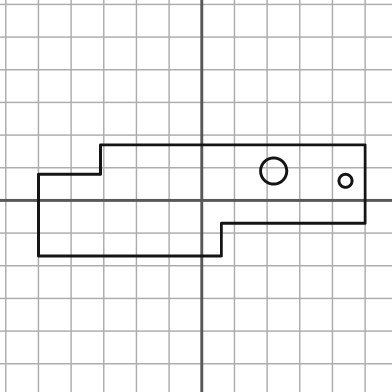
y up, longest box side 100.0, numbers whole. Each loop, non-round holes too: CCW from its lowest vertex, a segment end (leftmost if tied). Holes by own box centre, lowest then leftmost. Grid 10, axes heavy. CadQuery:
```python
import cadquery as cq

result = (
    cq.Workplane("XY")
    .moveTo(-50.0, -17.0)
    .lineTo(6.0, -17.0)
    .lineTo(6.0, -7.0)
    .lineTo(50.0, -7.0)
    .lineTo(50.0, 17.0)
    .lineTo(-31.0, 17.0)
    .lineTo(-31.0, 8.0)
    .lineTo(-50.0, 8.0)
    .close()
    .moveTo(44.0, 6.0)
    .circle(2.0)
    .moveTo(22.0, 9.0)
    .circle(4.0)
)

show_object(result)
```